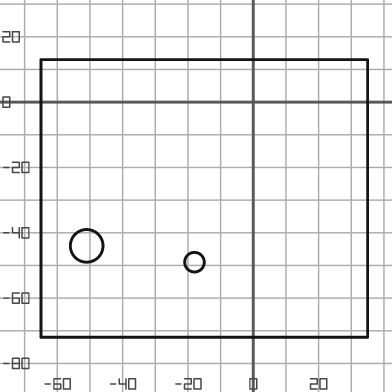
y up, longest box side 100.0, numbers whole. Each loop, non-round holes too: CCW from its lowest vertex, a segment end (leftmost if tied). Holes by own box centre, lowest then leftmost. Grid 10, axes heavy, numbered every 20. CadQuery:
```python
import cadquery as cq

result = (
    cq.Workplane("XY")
    .moveTo(-65.0, -72.0)
    .lineTo(35.0, -72.0)
    .lineTo(35.0, 13.0)
    .lineTo(-65.0, 13.0)
    .close()
    .moveTo(-18.0, -49.0)
    .circle(3.0)
    .moveTo(-51.0, -44.0)
    .circle(5.0)
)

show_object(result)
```